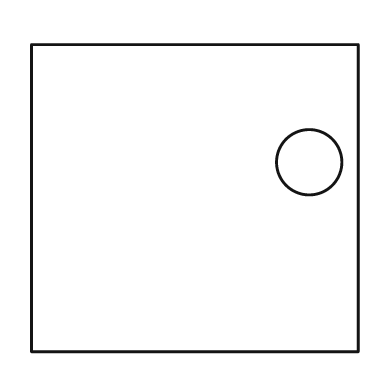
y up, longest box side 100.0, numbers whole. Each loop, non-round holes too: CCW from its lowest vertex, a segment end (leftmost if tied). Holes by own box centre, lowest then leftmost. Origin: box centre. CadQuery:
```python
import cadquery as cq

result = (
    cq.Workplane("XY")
    .moveTo(-50.0, -47.0)
    .lineTo(50.0, -47.0)
    .lineTo(50.0, 47.0)
    .lineTo(-50.0, 47.0)
    .close()
    .moveTo(35.0, 11.0)
    .circle(10.0)
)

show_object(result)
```